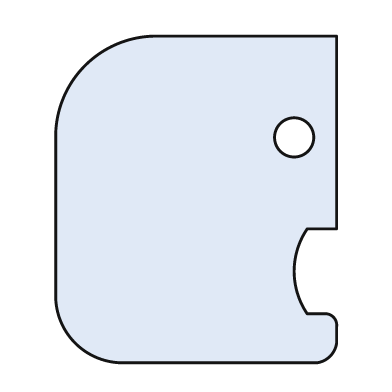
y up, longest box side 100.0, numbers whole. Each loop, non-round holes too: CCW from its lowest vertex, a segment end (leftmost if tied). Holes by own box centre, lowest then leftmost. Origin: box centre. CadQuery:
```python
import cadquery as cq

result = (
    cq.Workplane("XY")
    .moveTo(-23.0, -50.0)
    .lineTo(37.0, -50.0)
    .threePointArc((41.0, -48.0), (43.0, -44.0))
    .lineTo(43.0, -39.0)
    .threePointArc((42.0, -36.0), (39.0, -35.0))
    .lineTo(34.0, -35.0)
    .threePointArc((30.0, -22.0), (34.0, -9.0))
    .lineTo(43.0, -9.0)
    .lineTo(43.0, 50.0)
    .lineTo(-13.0, 50.0)
    .threePointArc((-34.0, 41.0), (-43.0, 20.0))
    .lineTo(-43.0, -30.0)
    .threePointArc((-37.0, -44.0), (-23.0, -50.0))
    .close()
    .moveTo(30.0, 19.0)
    .circle(6.0)
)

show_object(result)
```